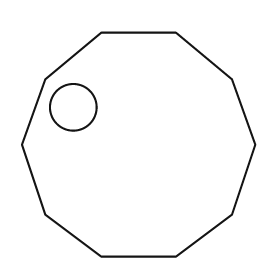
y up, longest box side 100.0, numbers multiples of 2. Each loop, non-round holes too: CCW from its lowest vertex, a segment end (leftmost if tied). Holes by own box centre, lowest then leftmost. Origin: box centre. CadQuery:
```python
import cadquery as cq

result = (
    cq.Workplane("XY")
    .moveTo(-16.0, -48.0)
    .lineTo(16.0, -48.0)
    .lineTo(40.0, -30.0)
    .lineTo(50.0, 0.0)
    .lineTo(40.0, 28.0)
    .lineTo(16.0, 48.0)
    .lineTo(-16.0, 48.0)
    .lineTo(-40.0, 28.0)
    .lineTo(-50.0, 0.0)
    .lineTo(-40.0, -30.0)
    .close()
    .moveTo(-28.0, 16.0)
    .circle(10.0)
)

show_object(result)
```